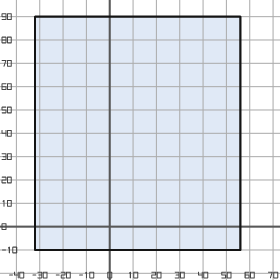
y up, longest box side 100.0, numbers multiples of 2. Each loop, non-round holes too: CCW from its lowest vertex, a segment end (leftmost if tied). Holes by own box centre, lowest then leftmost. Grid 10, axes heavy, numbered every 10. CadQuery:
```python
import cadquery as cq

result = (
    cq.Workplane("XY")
    .moveTo(-32.0, -10.0)
    .lineTo(56.0, -10.0)
    .lineTo(56.0, 90.0)
    .lineTo(-32.0, 90.0)
    .close()
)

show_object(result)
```